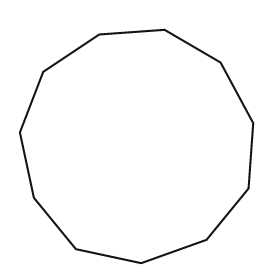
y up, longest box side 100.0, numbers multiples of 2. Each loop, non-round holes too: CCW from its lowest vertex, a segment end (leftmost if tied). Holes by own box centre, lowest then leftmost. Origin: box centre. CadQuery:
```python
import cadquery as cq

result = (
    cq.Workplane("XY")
    .moveTo(2.0, -50.0)
    .lineTo(30.0, -40.0)
    .lineTo(48.0, -18.0)
    .lineTo(50.0, 10.0)
    .lineTo(36.0, 36.0)
    .lineTo(12.0, 50.0)
    .lineTo(-16.0, 48.0)
    .lineTo(-40.0, 32.0)
    .lineTo(-50.0, 6.0)
    .lineTo(-44.0, -22.0)
    .lineTo(-26.0, -44.0)
    .close()
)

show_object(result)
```